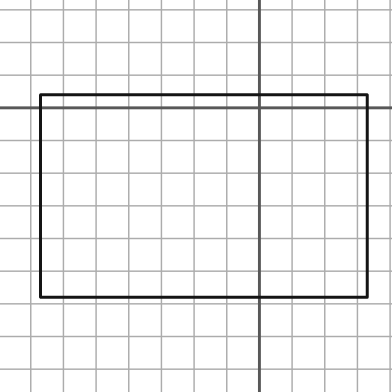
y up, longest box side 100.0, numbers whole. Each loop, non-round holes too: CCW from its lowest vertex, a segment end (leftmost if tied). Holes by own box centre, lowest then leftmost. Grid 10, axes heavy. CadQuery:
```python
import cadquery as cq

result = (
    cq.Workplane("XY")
    .moveTo(-67.0, -58.0)
    .lineTo(33.0, -58.0)
    .lineTo(33.0, 4.0)
    .lineTo(-67.0, 4.0)
    .close()
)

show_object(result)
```